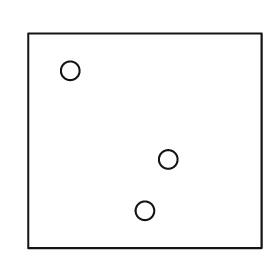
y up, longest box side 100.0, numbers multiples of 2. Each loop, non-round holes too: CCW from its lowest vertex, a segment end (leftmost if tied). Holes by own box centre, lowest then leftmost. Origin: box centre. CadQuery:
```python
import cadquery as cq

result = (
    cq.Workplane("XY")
    .moveTo(-50.0, -46.0)
    .lineTo(50.0, -46.0)
    .lineTo(50.0, 46.0)
    .lineTo(-50.0, 46.0)
    .close()
    .moveTo(0.0, -30.0)
    .circle(4.0)
    .moveTo(10.0, -8.0)
    .circle(4.0)
    .moveTo(-32.0, 30.0)
    .circle(4.0)
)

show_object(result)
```